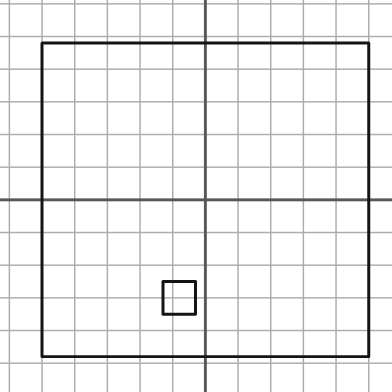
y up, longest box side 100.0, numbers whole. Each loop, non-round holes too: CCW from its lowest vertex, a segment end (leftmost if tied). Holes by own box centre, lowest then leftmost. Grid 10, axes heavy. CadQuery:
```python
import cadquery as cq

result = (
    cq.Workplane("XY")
    .moveTo(-50.0, -48.0)
    .lineTo(50.0, -48.0)
    .lineTo(50.0, 48.0)
    .lineTo(-50.0, 48.0)
    .close()
    .moveTo(-13.0, -35.0)
    .lineTo(-3.0, -35.0)
    .lineTo(-3.0, -25.0)
    .lineTo(-13.0, -25.0)
    .close()
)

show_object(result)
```